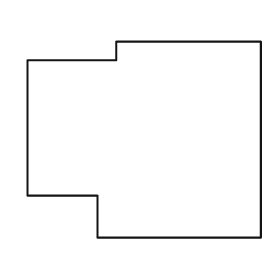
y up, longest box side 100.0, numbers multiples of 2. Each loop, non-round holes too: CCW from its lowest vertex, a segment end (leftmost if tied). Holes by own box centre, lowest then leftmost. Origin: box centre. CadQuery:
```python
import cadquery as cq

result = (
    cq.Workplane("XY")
    .moveTo(-20.0, -42.0)
    .lineTo(50.0, -42.0)
    .lineTo(50.0, 42.0)
    .lineTo(-12.0, 42.0)
    .lineTo(-12.0, 34.0)
    .lineTo(-50.0, 34.0)
    .lineTo(-50.0, -24.0)
    .lineTo(-20.0, -24.0)
    .close()
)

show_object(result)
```